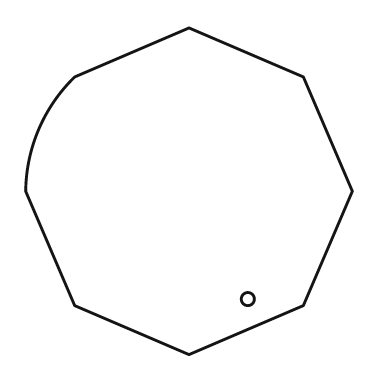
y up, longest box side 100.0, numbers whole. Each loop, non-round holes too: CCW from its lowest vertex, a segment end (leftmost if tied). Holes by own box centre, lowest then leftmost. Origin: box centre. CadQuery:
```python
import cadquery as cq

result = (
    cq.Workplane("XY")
    .moveTo(0.0, -50.0)
    .lineTo(35.0, -35.0)
    .lineTo(50.0, 0.0)
    .lineTo(35.0, 35.0)
    .lineTo(0.0, 50.0)
    .lineTo(-35.0, 35.0)
    .threePointArc((-46.0, 19.0), (-50.0, 0.0))
    .lineTo(-35.0, -35.0)
    .close()
    .moveTo(18.0, -33.0)
    .circle(2.0)
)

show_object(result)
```